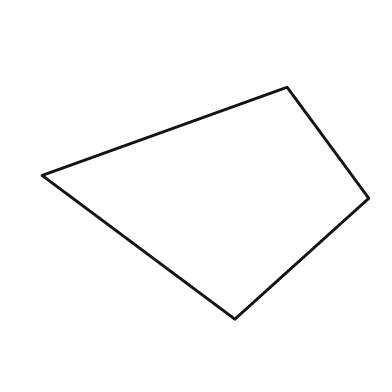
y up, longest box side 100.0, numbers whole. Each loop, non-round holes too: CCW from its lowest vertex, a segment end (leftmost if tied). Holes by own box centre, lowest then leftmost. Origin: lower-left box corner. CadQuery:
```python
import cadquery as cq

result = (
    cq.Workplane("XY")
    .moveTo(59.0, 0.0)
    .lineTo(100.0, 37.0)
    .lineTo(75.0, 71.0)
    .lineTo(0.0, 44.0)
    .close()
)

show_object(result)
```